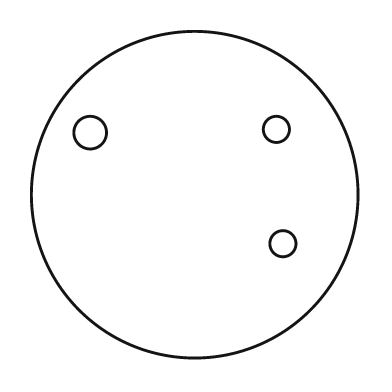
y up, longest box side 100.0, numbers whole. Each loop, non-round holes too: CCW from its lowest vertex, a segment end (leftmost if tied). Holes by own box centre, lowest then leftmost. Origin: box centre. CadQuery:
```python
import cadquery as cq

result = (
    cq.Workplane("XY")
    .moveTo(0.0, 0.0)
    .circle(50.0)
    .moveTo(27.0, -15.0)
    .circle(4.0)
    .moveTo(-32.0, 19.0)
    .circle(5.0)
    .moveTo(25.0, 20.0)
    .circle(4.0)
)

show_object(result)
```